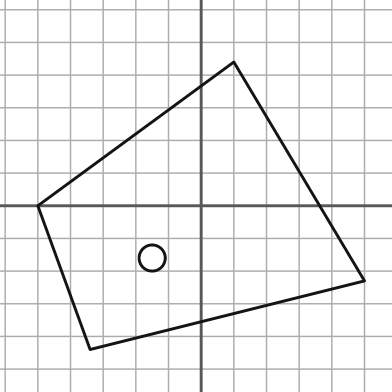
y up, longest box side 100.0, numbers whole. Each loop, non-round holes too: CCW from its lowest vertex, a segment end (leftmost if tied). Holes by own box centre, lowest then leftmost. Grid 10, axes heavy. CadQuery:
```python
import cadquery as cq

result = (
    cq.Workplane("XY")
    .moveTo(-34.0, -44.0)
    .lineTo(50.0, -23.0)
    .lineTo(10.0, 44.0)
    .lineTo(-50.0, 0.0)
    .close()
    .moveTo(-15.0, -16.0)
    .circle(4.0)
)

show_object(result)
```